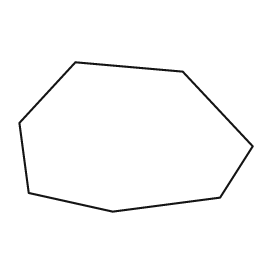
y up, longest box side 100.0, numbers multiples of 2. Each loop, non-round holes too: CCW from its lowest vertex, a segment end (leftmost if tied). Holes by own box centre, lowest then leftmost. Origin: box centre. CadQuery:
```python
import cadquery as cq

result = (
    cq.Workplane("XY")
    .moveTo(-10.0, -32.0)
    .lineTo(36.0, -26.0)
    .lineTo(50.0, -4.0)
    .lineTo(20.0, 28.0)
    .lineTo(-26.0, 32.0)
    .lineTo(-50.0, 6.0)
    .lineTo(-46.0, -24.0)
    .close()
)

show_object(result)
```